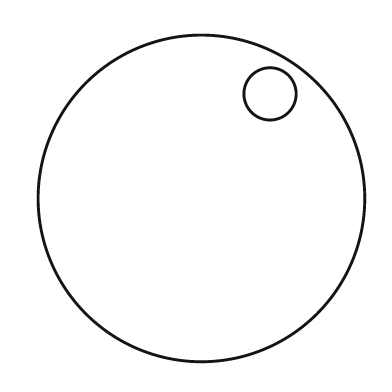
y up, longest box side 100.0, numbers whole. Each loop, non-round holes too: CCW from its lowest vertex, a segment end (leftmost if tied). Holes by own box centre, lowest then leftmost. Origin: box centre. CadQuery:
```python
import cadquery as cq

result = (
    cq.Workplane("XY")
    .moveTo(0.0, 0.0)
    .circle(50.0)
    .moveTo(21.0, 32.0)
    .circle(8.0)
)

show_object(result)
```